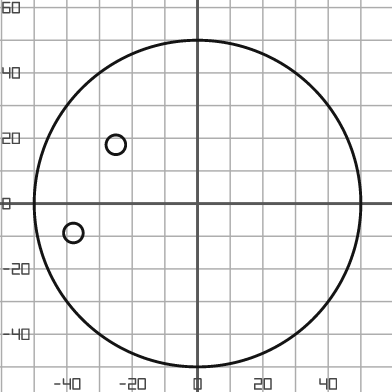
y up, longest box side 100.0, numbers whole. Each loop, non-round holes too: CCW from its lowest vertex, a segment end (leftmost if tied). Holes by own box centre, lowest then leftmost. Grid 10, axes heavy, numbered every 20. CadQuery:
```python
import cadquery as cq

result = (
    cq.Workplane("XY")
    .moveTo(0.0, 0.0)
    .circle(50.0)
    .moveTo(-38.0, -9.0)
    .circle(3.0)
    .moveTo(-25.0, 18.0)
    .circle(3.0)
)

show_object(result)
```